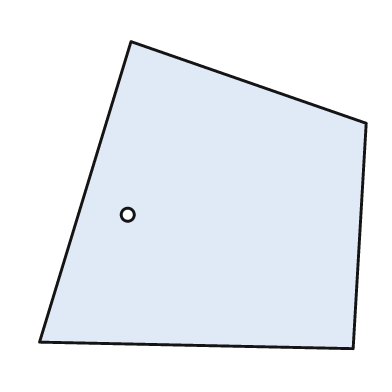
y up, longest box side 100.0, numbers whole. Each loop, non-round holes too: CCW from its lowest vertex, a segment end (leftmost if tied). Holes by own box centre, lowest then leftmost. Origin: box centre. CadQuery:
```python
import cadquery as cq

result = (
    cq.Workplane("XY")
    .moveTo(46.0, -47.0)
    .lineTo(50.0, 22.0)
    .lineTo(-22.0, 47.0)
    .lineTo(-50.0, -45.0)
    .close()
    .moveTo(-23.0, -6.0)
    .circle(2.0)
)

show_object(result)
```